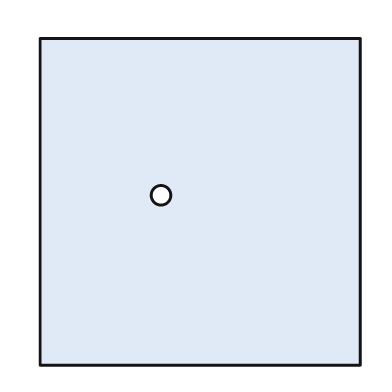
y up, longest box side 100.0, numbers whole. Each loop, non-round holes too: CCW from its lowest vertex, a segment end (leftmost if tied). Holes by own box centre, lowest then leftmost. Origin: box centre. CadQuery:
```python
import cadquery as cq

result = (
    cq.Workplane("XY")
    .moveTo(-49.0, -50.0)
    .lineTo(49.0, -50.0)
    .lineTo(49.0, 50.0)
    .lineTo(-49.0, 50.0)
    .close()
    .moveTo(-12.0, 2.0)
    .circle(3.0)
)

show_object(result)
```